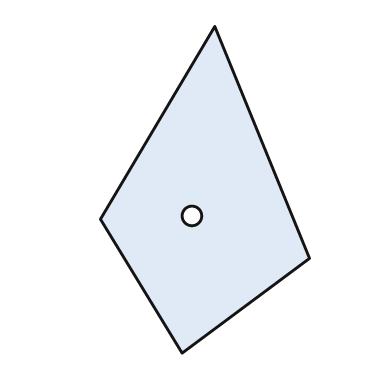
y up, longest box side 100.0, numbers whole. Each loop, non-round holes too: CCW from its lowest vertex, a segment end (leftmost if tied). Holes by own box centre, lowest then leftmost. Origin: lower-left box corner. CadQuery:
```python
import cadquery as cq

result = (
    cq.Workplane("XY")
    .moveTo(25.0, 0.0)
    .lineTo(64.0, 29.0)
    .lineTo(35.0, 100.0)
    .lineTo(0.0, 41.0)
    .close()
    .moveTo(28.0, 42.0)
    .circle(3.0)
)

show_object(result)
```